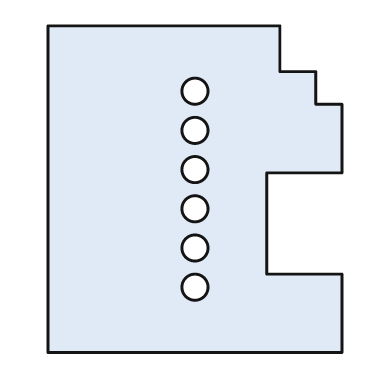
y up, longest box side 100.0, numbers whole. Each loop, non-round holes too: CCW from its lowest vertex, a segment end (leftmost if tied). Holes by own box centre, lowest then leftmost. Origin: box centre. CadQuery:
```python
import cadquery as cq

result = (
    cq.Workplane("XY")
    .moveTo(-45.0, -50.0)
    .lineTo(45.0, -50.0)
    .lineTo(45.0, -26.0)
    .lineTo(22.0, -26.0)
    .lineTo(22.0, 5.0)
    .lineTo(45.0, 5.0)
    .lineTo(45.0, 26.0)
    .lineTo(37.0, 26.0)
    .lineTo(37.0, 36.0)
    .lineTo(26.0, 36.0)
    .lineTo(26.0, 50.0)
    .lineTo(-45.0, 50.0)
    .close()
    .moveTo(0.0, -30.0)
    .circle(4.0)
    .moveTo(0.0, -18.0)
    .circle(4.0)
    .moveTo(0.0, -6.0)
    .circle(4.0)
    .moveTo(0.0, 6.0)
    .circle(4.0)
    .moveTo(0.0, 18.0)
    .circle(4.0)
    .moveTo(0.0, 30.0)
    .circle(4.0)
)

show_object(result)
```